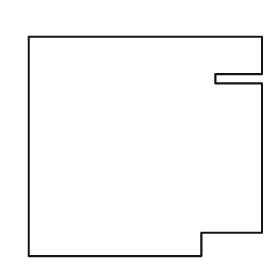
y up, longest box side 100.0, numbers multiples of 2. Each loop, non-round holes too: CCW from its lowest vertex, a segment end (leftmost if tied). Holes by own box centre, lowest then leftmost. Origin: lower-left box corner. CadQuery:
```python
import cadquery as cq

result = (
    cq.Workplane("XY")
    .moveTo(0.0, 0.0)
    .lineTo(74.0, 0.0)
    .lineTo(74.0, 10.0)
    .lineTo(100.0, 10.0)
    .lineTo(100.0, 74.0)
    .lineTo(80.0, 74.0)
    .lineTo(80.0, 78.0)
    .lineTo(100.0, 78.0)
    .lineTo(100.0, 94.0)
    .lineTo(0.0, 94.0)
    .close()
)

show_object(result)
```